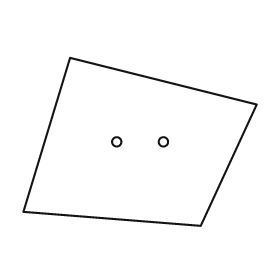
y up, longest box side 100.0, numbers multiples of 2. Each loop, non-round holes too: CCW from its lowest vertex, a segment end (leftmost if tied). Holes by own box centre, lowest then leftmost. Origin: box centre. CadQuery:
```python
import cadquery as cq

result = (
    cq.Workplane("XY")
    .moveTo(26.0, -36.0)
    .lineTo(50.0, 16.0)
    .lineTo(-30.0, 36.0)
    .lineTo(-50.0, -30.0)
    .close()
    .moveTo(-10.0, 0.0)
    .circle(2.0)
    .moveTo(10.0, 0.0)
    .circle(2.0)
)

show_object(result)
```